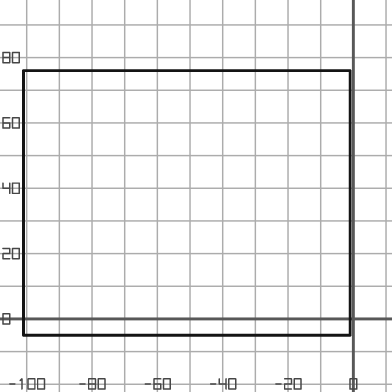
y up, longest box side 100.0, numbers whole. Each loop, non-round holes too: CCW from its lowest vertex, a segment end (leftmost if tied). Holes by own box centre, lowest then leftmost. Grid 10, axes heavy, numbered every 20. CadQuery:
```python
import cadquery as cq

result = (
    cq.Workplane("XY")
    .moveTo(-101.0, -5.0)
    .lineTo(-1.0, -5.0)
    .lineTo(-1.0, 76.0)
    .lineTo(-101.0, 76.0)
    .close()
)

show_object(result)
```